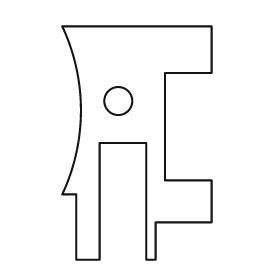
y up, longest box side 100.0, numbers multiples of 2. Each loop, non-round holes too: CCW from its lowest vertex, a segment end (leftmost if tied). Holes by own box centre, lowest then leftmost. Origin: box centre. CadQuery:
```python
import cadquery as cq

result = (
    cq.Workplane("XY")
    .moveTo(-26.0, -50.0)
    .lineTo(-16.0, -50.0)
    .lineTo(-16.0, 0.0)
    .lineTo(4.0, 0.0)
    .lineTo(4.0, -50.0)
    .lineTo(8.0, -50.0)
    .lineTo(8.0, -34.0)
    .lineTo(32.0, -34.0)
    .lineTo(32.0, -16.0)
    .lineTo(12.0, -16.0)
    .lineTo(12.0, 30.0)
    .lineTo(32.0, 30.0)
    .lineTo(32.0, 50.0)
    .lineTo(-32.0, 50.0)
    .threePointArc((-24.0, 14.0), (-32.0, -22.0))
    .lineTo(-26.0, -22.0)
    .close()
    .moveTo(-8.0, 18.0)
    .circle(6.0)
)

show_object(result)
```